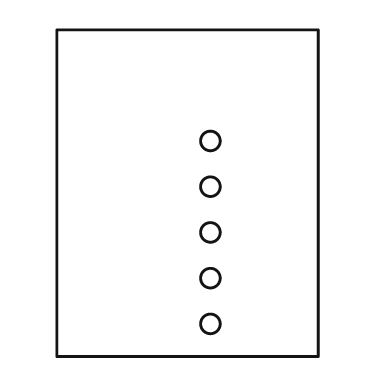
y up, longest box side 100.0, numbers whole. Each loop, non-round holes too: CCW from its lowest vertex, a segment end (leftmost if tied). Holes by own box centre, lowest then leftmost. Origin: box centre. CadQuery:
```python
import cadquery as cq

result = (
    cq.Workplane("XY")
    .moveTo(-40.0, -50.0)
    .lineTo(40.0, -50.0)
    .lineTo(40.0, 50.0)
    .lineTo(-40.0, 50.0)
    .close()
    .moveTo(7.0, -40.0)
    .circle(3.0)
    .moveTo(7.0, -26.0)
    .circle(3.0)
    .moveTo(7.0, -12.0)
    .circle(3.0)
    .moveTo(7.0, 2.0)
    .circle(3.0)
    .moveTo(7.0, 16.0)
    .circle(3.0)
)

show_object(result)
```